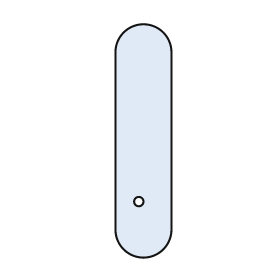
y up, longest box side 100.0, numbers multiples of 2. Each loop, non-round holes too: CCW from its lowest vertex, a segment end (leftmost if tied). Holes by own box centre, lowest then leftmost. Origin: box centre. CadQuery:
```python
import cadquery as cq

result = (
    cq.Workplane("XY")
    .moveTo(-12.0, -38.0)
    .threePointArc((0.0, -50.0), (12.0, -38.0))
    .lineTo(12.0, 38.0)
    .threePointArc((0.0, 50.0), (-12.0, 38.0))
    .close()
    .moveTo(-2.0, -26.0)
    .circle(2.0)
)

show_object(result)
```